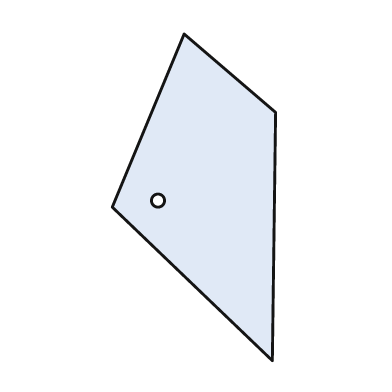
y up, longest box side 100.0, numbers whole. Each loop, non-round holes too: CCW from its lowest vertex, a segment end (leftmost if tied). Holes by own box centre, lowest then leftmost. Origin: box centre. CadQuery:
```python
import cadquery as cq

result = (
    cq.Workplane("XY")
    .moveTo(24.0, -50.0)
    .lineTo(25.0, 26.0)
    .lineTo(-3.0, 50.0)
    .lineTo(-25.0, -3.0)
    .close()
    .moveTo(-11.0, -1.0)
    .circle(2.0)
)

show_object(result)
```